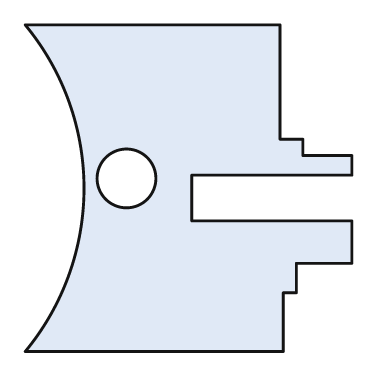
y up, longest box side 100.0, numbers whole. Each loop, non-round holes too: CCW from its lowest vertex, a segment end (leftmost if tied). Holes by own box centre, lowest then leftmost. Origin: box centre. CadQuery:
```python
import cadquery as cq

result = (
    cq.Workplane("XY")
    .moveTo(-50.0, -50.0)
    .lineTo(29.0, -50.0)
    .lineTo(29.0, -32.0)
    .lineTo(33.0, -32.0)
    .lineTo(33.0, -23.0)
    .lineTo(50.0, -23.0)
    .lineTo(50.0, -10.0)
    .lineTo(1.0, -10.0)
    .lineTo(1.0, 4.0)
    .lineTo(50.0, 4.0)
    .lineTo(50.0, 10.0)
    .lineTo(35.0, 10.0)
    .lineTo(35.0, 15.0)
    .lineTo(28.0, 15.0)
    .lineTo(28.0, 50.0)
    .lineTo(-50.0, 50.0)
    .threePointArc((-32.0, 0.0), (-50.0, -50.0))
    .close()
    .moveTo(-19.0, 3.0)
    .circle(9.0)
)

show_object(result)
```